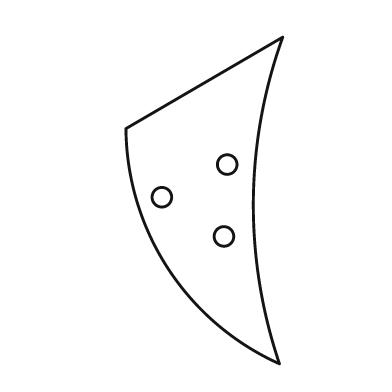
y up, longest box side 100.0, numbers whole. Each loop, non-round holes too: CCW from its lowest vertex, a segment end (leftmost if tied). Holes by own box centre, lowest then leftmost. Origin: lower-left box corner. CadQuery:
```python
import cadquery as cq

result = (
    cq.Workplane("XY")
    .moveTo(47.0, 0.0)
    .threePointArc((39.0, 50.0), (48.0, 100.0))
    .lineTo(0.0, 72.0)
    .threePointArc((13.0, 29.0), (47.0, 0.0))
    .close()
    .moveTo(30.0, 39.0)
    .circle(3.0)
    .moveTo(11.0, 51.0)
    .circle(3.0)
    .moveTo(31.0, 61.0)
    .circle(3.0)
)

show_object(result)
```